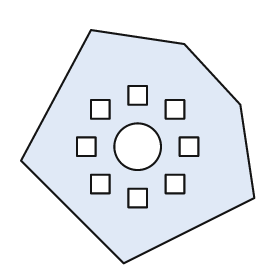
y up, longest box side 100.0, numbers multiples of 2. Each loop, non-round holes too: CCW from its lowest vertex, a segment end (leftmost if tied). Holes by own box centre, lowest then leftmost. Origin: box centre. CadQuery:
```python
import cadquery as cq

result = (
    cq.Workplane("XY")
    .moveTo(-6.0, -50.0)
    .lineTo(50.0, -22.0)
    .lineTo(44.0, 18.0)
    .lineTo(20.0, 44.0)
    .lineTo(-20.0, 50.0)
    .lineTo(-50.0, -6.0)
    .close()
    .moveTo(-4.0, -26.0)
    .lineTo(4.0, -26.0)
    .lineTo(4.0, -18.0)
    .lineTo(-4.0, -18.0)
    .close()
    .moveTo(-20.0, -20.0)
    .lineTo(-12.0, -20.0)
    .lineTo(-12.0, -12.0)
    .lineTo(-20.0, -12.0)
    .close()
    .moveTo(12.0, -20.0)
    .lineTo(20.0, -20.0)
    .lineTo(20.0, -12.0)
    .lineTo(12.0, -12.0)
    .close()
    .moveTo(-26.0, -4.0)
    .lineTo(-18.0, -4.0)
    .lineTo(-18.0, 4.0)
    .lineTo(-26.0, 4.0)
    .close()
    .moveTo(0.0, 0.0)
    .circle(10.0)
    .moveTo(18.0, -4.0)
    .lineTo(26.0, -4.0)
    .lineTo(26.0, 4.0)
    .lineTo(18.0, 4.0)
    .close()
    .moveTo(-20.0, 12.0)
    .lineTo(-12.0, 12.0)
    .lineTo(-12.0, 20.0)
    .lineTo(-20.0, 20.0)
    .close()
    .moveTo(12.0, 12.0)
    .lineTo(20.0, 12.0)
    .lineTo(20.0, 20.0)
    .lineTo(12.0, 20.0)
    .close()
    .moveTo(-4.0, 18.0)
    .lineTo(4.0, 18.0)
    .lineTo(4.0, 26.0)
    .lineTo(-4.0, 26.0)
    .close()
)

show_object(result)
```